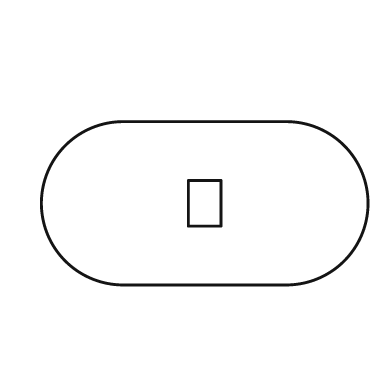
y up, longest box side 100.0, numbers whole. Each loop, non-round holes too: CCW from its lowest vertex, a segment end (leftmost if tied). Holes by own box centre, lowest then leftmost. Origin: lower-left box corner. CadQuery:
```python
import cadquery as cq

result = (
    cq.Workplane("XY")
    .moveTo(25.0, 0.0)
    .lineTo(75.0, 0.0)
    .threePointArc((100.0, 25.0), (75.0, 50.0))
    .lineTo(25.0, 50.0)
    .threePointArc((0.0, 25.0), (25.0, 0.0))
    .close()
    .moveTo(45.0, 18.0)
    .lineTo(55.0, 18.0)
    .lineTo(55.0, 32.0)
    .lineTo(45.0, 32.0)
    .close()
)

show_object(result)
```